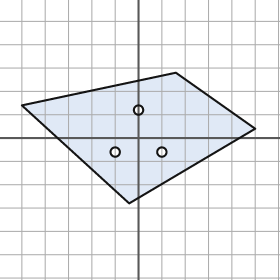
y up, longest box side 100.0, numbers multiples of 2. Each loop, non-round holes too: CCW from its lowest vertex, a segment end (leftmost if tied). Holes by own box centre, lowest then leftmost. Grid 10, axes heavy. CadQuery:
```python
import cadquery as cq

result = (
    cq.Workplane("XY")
    .moveTo(-4.0, -28.0)
    .lineTo(50.0, 4.0)
    .lineTo(16.0, 28.0)
    .lineTo(-50.0, 14.0)
    .close()
    .moveTo(-10.0, -6.0)
    .circle(2.0)
    .moveTo(10.0, -6.0)
    .circle(2.0)
    .moveTo(0.0, 12.0)
    .circle(2.0)
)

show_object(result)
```